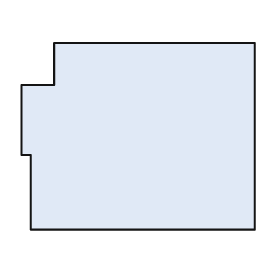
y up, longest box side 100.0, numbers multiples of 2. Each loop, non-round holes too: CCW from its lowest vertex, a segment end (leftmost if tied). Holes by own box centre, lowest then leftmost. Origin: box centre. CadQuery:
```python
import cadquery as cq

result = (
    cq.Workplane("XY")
    .moveTo(-46.0, -40.0)
    .lineTo(50.0, -40.0)
    .lineTo(50.0, 40.0)
    .lineTo(-36.0, 40.0)
    .lineTo(-36.0, 22.0)
    .lineTo(-50.0, 22.0)
    .lineTo(-50.0, -8.0)
    .lineTo(-46.0, -8.0)
    .close()
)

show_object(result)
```